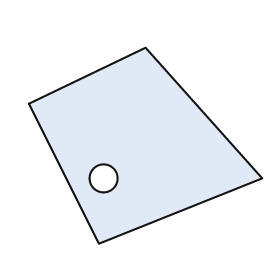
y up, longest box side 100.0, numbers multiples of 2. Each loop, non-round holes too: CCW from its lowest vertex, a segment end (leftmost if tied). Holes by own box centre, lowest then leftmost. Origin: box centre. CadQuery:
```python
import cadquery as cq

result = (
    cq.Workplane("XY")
    .moveTo(-20.0, -42.0)
    .lineTo(50.0, -14.0)
    .lineTo(0.0, 42.0)
    .lineTo(-50.0, 18.0)
    .close()
    .moveTo(-18.0, -14.0)
    .circle(6.0)
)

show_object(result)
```